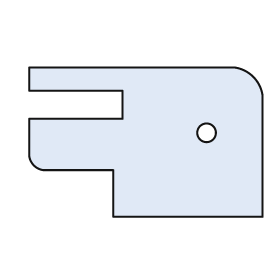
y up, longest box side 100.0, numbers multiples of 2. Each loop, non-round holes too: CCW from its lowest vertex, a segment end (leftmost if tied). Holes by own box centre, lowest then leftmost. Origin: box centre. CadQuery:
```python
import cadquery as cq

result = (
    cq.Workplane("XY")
    .moveTo(-14.0, -32.0)
    .lineTo(50.0, -32.0)
    .lineTo(50.0, 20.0)
    .threePointArc((46.0, 28.0), (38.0, 32.0))
    .lineTo(-50.0, 32.0)
    .lineTo(-50.0, 22.0)
    .lineTo(-10.0, 22.0)
    .lineTo(-10.0, 10.0)
    .lineTo(-50.0, 10.0)
    .lineTo(-50.0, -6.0)
    .threePointArc((-48.0, -10.0), (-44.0, -12.0))
    .lineTo(-14.0, -12.0)
    .close()
    .moveTo(26.0, 4.0)
    .circle(4.0)
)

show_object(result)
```